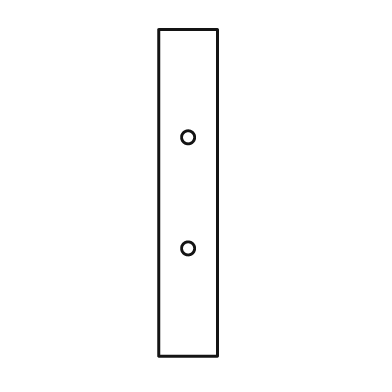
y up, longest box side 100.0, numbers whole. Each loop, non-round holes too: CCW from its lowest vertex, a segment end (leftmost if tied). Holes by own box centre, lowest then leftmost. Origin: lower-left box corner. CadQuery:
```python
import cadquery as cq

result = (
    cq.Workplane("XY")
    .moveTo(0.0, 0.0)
    .lineTo(18.0, 0.0)
    .lineTo(18.0, 100.0)
    .lineTo(0.0, 100.0)
    .close()
    .moveTo(9.0, 33.0)
    .circle(2.0)
    .moveTo(9.0, 67.0)
    .circle(2.0)
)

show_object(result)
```